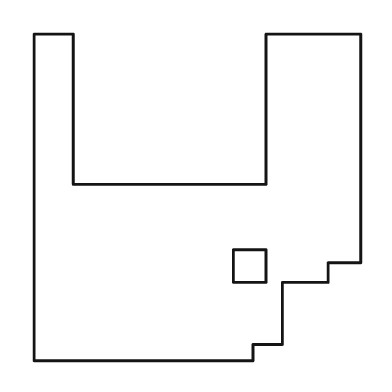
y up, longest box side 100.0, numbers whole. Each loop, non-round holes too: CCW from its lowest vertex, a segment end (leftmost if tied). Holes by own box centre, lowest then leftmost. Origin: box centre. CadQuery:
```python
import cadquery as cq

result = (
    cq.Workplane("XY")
    .moveTo(-50.0, -50.0)
    .lineTo(17.0, -50.0)
    .lineTo(17.0, -45.0)
    .lineTo(26.0, -45.0)
    .lineTo(26.0, -26.0)
    .lineTo(40.0, -26.0)
    .lineTo(40.0, -20.0)
    .lineTo(50.0, -20.0)
    .lineTo(50.0, 50.0)
    .lineTo(21.0, 50.0)
    .lineTo(21.0, 4.0)
    .lineTo(-38.0, 4.0)
    .lineTo(-38.0, 50.0)
    .lineTo(-50.0, 50.0)
    .close()
    .moveTo(11.0, -26.0)
    .lineTo(21.0, -26.0)
    .lineTo(21.0, -16.0)
    .lineTo(11.0, -16.0)
    .close()
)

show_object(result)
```